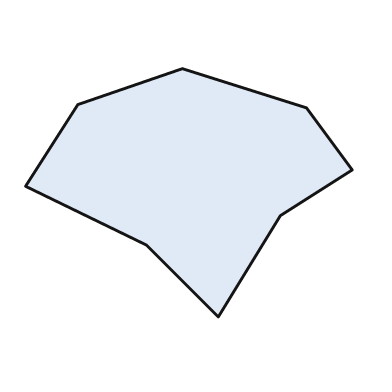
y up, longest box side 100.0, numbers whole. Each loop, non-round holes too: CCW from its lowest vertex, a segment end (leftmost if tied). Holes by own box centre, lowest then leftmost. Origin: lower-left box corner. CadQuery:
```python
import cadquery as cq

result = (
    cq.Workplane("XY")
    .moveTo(59.0, 0.0)
    .lineTo(78.0, 31.0)
    .lineTo(100.0, 45.0)
    .lineTo(86.0, 64.0)
    .lineTo(48.0, 76.0)
    .lineTo(16.0, 65.0)
    .lineTo(0.0, 40.0)
    .lineTo(37.0, 22.0)
    .close()
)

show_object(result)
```